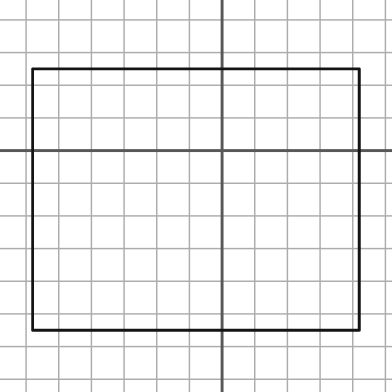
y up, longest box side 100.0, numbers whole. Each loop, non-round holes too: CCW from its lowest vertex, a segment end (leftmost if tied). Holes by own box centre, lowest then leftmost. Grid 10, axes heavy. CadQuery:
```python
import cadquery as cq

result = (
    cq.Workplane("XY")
    .moveTo(-58.0, -55.0)
    .lineTo(42.0, -55.0)
    .lineTo(42.0, 25.0)
    .lineTo(-58.0, 25.0)
    .close()
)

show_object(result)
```